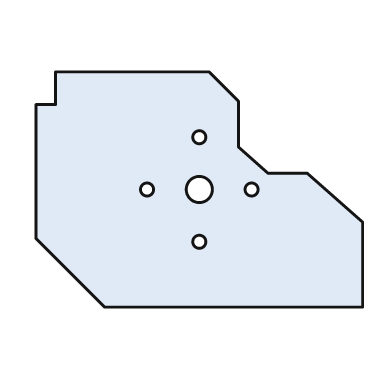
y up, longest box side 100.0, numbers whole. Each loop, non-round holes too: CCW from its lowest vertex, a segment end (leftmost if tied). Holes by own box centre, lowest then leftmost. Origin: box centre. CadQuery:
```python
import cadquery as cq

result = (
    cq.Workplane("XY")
    .moveTo(-29.0, -36.0)
    .lineTo(50.0, -36.0)
    .lineTo(50.0, -10.0)
    .lineTo(33.0, 5.0)
    .lineTo(21.0, 5.0)
    .lineTo(12.0, 13.0)
    .lineTo(12.0, 27.0)
    .lineTo(3.0, 36.0)
    .lineTo(-44.0, 36.0)
    .lineTo(-44.0, 26.0)
    .lineTo(-50.0, 26.0)
    .lineTo(-50.0, -15.0)
    .close()
    .moveTo(0.0, -16.0)
    .circle(2.0)
    .moveTo(-16.0, 0.0)
    .circle(2.0)
    .moveTo(0.0, 0.0)
    .circle(4.0)
    .moveTo(16.0, 0.0)
    .circle(2.0)
    .moveTo(0.0, 16.0)
    .circle(2.0)
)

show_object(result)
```